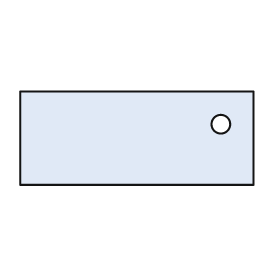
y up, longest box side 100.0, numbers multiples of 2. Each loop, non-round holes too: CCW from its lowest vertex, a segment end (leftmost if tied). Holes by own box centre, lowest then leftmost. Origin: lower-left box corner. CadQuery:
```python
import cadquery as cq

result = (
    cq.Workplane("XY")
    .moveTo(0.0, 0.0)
    .lineTo(100.0, 0.0)
    .lineTo(100.0, 40.0)
    .lineTo(0.0, 40.0)
    .close()
    .moveTo(86.0, 26.0)
    .circle(4.0)
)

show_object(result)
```